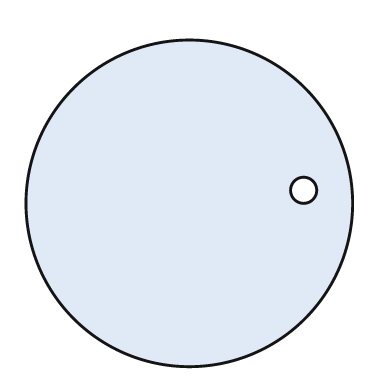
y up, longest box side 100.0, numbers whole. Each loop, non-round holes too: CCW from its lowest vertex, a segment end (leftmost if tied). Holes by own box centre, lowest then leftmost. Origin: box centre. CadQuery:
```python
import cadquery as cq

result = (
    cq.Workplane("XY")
    .moveTo(0.0, 0.0)
    .circle(50.0)
    .moveTo(35.0, 4.0)
    .circle(4.0)
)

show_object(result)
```